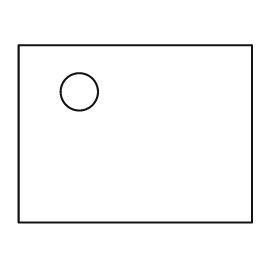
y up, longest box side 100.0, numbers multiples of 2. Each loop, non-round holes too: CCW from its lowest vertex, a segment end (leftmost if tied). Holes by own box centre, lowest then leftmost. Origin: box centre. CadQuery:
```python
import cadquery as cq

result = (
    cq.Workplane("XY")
    .moveTo(-50.0, -38.0)
    .lineTo(50.0, -38.0)
    .lineTo(50.0, 38.0)
    .lineTo(-50.0, 38.0)
    .close()
    .moveTo(-24.0, 18.0)
    .circle(8.0)
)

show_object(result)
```